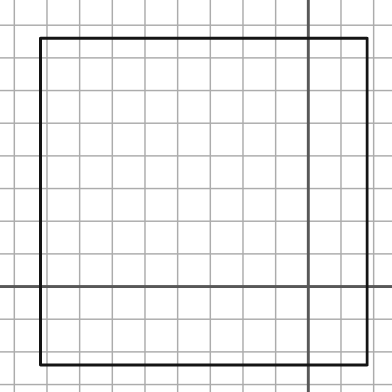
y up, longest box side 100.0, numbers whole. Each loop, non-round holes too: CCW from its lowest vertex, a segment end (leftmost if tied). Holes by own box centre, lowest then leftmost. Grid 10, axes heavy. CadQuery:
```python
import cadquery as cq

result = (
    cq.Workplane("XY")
    .moveTo(-82.0, -24.0)
    .lineTo(18.0, -24.0)
    .lineTo(18.0, 76.0)
    .lineTo(-82.0, 76.0)
    .close()
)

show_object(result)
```